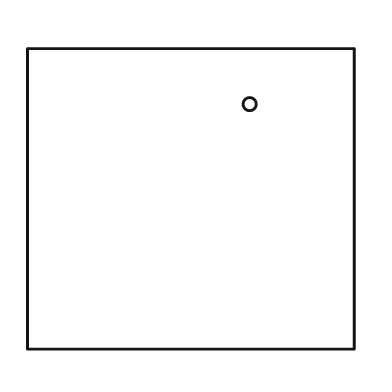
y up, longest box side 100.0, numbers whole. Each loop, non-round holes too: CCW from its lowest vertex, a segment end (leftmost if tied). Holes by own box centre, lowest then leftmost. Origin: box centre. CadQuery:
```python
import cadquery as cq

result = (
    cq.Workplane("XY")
    .moveTo(-50.0, -46.0)
    .lineTo(50.0, -46.0)
    .lineTo(50.0, 46.0)
    .lineTo(-50.0, 46.0)
    .close()
    .moveTo(18.0, 29.0)
    .circle(2.0)
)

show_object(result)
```